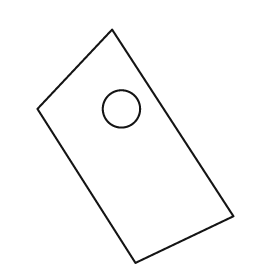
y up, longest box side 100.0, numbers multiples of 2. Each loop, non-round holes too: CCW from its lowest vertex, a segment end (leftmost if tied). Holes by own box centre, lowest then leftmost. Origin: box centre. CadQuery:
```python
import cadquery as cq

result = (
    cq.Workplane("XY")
    .moveTo(0.0, -50.0)
    .lineTo(42.0, -30.0)
    .lineTo(-10.0, 50.0)
    .lineTo(-42.0, 16.0)
    .close()
    .moveTo(-6.0, 16.0)
    .circle(8.0)
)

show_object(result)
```